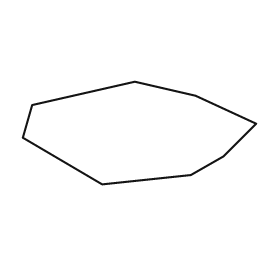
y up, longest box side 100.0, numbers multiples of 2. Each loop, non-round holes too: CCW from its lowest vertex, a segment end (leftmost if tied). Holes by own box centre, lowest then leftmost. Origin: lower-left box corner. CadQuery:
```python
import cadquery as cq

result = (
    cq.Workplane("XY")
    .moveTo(34.0, 0.0)
    .lineTo(72.0, 4.0)
    .lineTo(86.0, 12.0)
    .lineTo(100.0, 26.0)
    .lineTo(74.0, 38.0)
    .lineTo(48.0, 44.0)
    .lineTo(4.0, 34.0)
    .lineTo(0.0, 20.0)
    .close()
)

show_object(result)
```